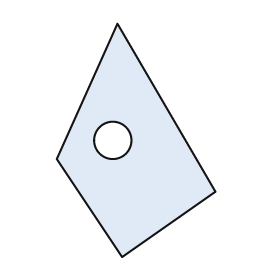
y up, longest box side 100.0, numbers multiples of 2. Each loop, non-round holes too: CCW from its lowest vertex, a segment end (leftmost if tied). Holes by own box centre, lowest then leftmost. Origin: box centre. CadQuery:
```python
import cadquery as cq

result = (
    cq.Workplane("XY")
    .moveTo(-6.0, -50.0)
    .lineTo(34.0, -22.0)
    .lineTo(-8.0, 50.0)
    .lineTo(-34.0, -8.0)
    .close()
    .moveTo(-10.0, 0.0)
    .circle(8.0)
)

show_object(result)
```